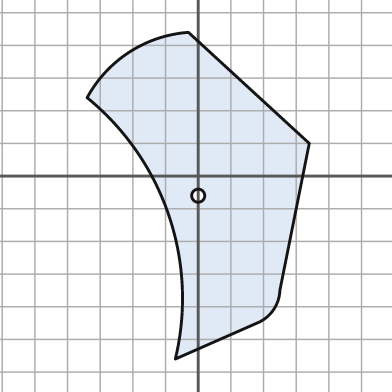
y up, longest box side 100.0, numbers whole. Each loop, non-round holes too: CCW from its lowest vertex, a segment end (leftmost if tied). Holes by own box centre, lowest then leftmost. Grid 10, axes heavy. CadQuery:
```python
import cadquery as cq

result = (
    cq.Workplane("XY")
    .moveTo(-7.0, -56.0)
    .lineTo(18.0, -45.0)
    .threePointArc((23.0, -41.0), (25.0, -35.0))
    .lineTo(34.0, 10.0)
    .lineTo(-3.0, 44.0)
    .threePointArc((-21.0, 38.0), (-34.0, 24.0))
    .threePointArc((-9.0, -12.0), (-7.0, -56.0))
    .close()
    .moveTo(0.0, -6.0)
    .circle(2.0)
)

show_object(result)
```